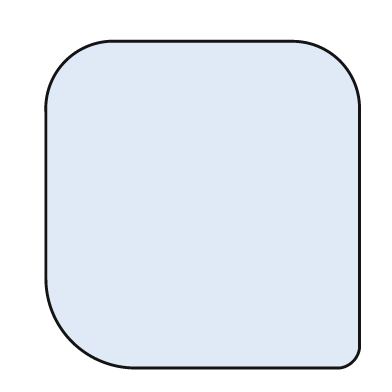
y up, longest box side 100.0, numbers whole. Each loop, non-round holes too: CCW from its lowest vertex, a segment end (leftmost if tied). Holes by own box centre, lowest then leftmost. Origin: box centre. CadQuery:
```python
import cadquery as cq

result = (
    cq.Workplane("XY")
    .moveTo(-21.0, -50.0)
    .lineTo(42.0, -50.0)
    .threePointArc((46.0, -48.0), (48.0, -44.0))
    .lineTo(48.0, 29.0)
    .threePointArc((42.0, 44.0), (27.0, 50.0))
    .lineTo(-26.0, 50.0)
    .threePointArc((-42.0, 44.0), (-48.0, 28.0))
    .lineTo(-48.0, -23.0)
    .threePointArc((-40.0, -42.0), (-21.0, -50.0))
    .close()
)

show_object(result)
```